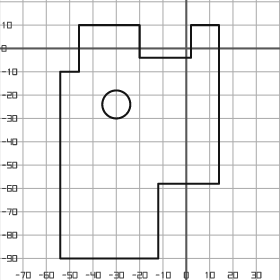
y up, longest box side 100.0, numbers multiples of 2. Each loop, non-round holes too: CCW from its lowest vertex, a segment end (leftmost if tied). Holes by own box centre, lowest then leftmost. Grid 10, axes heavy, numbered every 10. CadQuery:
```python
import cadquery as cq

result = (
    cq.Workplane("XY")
    .moveTo(-54.0, -90.0)
    .lineTo(-12.0, -90.0)
    .lineTo(-12.0, -58.0)
    .lineTo(14.0, -58.0)
    .lineTo(14.0, 10.0)
    .lineTo(2.0, 10.0)
    .lineTo(2.0, -4.0)
    .lineTo(-20.0, -4.0)
    .lineTo(-20.0, 10.0)
    .lineTo(-46.0, 10.0)
    .lineTo(-46.0, -10.0)
    .lineTo(-54.0, -10.0)
    .close()
    .moveTo(-30.0, -24.0)
    .circle(6.0)
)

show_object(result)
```